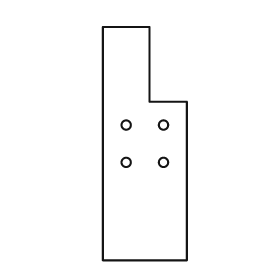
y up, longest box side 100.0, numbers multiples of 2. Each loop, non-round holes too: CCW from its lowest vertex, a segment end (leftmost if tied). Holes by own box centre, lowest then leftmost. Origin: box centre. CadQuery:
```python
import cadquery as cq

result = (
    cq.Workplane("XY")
    .moveTo(-18.0, -50.0)
    .lineTo(18.0, -50.0)
    .lineTo(18.0, 18.0)
    .lineTo(2.0, 18.0)
    .lineTo(2.0, 50.0)
    .lineTo(-18.0, 50.0)
    .close()
    .moveTo(-8.0, -8.0)
    .circle(2.0)
    .moveTo(8.0, -8.0)
    .circle(2.0)
    .moveTo(-8.0, 8.0)
    .circle(2.0)
    .moveTo(8.0, 8.0)
    .circle(2.0)
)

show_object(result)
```